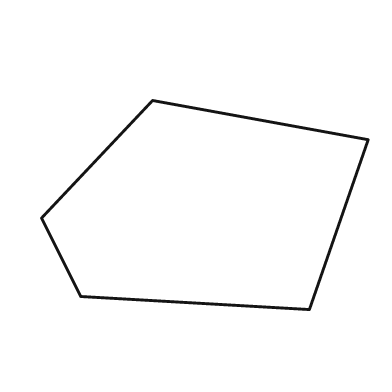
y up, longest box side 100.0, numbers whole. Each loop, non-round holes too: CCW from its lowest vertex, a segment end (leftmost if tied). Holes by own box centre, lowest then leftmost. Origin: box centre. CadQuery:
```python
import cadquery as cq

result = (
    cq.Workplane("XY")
    .moveTo(32.0, -32.0)
    .lineTo(50.0, 20.0)
    .lineTo(-16.0, 32.0)
    .lineTo(-50.0, -4.0)
    .lineTo(-38.0, -28.0)
    .close()
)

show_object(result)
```